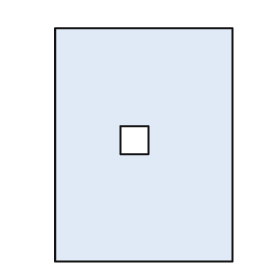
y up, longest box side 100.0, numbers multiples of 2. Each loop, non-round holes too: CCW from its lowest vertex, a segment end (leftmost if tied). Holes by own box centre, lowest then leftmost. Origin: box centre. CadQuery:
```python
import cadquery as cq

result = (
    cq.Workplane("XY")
    .moveTo(-38.0, -50.0)
    .lineTo(38.0, -50.0)
    .lineTo(38.0, 50.0)
    .lineTo(-38.0, 50.0)
    .close()
    .moveTo(-10.0, -4.0)
    .lineTo(2.0, -4.0)
    .lineTo(2.0, 8.0)
    .lineTo(-10.0, 8.0)
    .close()
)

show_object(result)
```